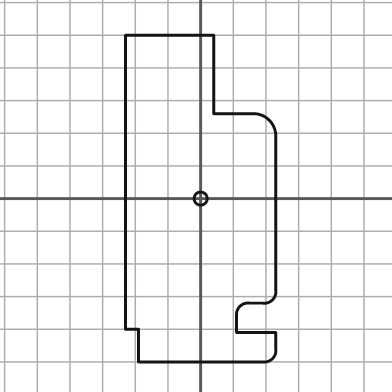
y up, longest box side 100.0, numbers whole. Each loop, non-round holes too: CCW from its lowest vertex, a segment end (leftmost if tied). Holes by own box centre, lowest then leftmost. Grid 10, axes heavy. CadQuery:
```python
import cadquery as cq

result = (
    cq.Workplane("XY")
    .moveTo(-19.0, -50.0)
    .lineTo(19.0, -50.0)
    .threePointArc((22.0, -49.0), (23.0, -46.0))
    .lineTo(23.0, -41.0)
    .lineTo(11.0, -41.0)
    .lineTo(11.0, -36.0)
    .threePointArc((12.0, -33.0), (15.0, -32.0))
    .lineTo(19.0, -32.0)
    .threePointArc((22.0, -31.0), (23.0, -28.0))
    .lineTo(23.0, 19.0)
    .threePointArc((21.0, 24.0), (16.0, 26.0))
    .lineTo(4.0, 26.0)
    .lineTo(4.0, 50.0)
    .lineTo(-23.0, 50.0)
    .lineTo(-23.0, -40.0)
    .lineTo(-19.0, -40.0)
    .close()
    .moveTo(0.0, 0.0)
    .circle(2.0)
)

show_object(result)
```